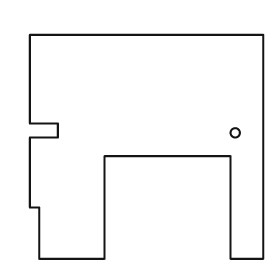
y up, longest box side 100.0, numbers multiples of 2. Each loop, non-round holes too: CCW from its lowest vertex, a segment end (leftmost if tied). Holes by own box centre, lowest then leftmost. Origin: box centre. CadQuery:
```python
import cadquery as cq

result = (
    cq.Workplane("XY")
    .moveTo(-46.0, -48.0)
    .lineTo(-18.0, -48.0)
    .lineTo(-18.0, -4.0)
    .lineTo(36.0, -4.0)
    .lineTo(36.0, -48.0)
    .lineTo(50.0, -48.0)
    .lineTo(50.0, 48.0)
    .lineTo(-50.0, 48.0)
    .lineTo(-50.0, 10.0)
    .lineTo(-38.0, 10.0)
    .lineTo(-38.0, 4.0)
    .lineTo(-50.0, 4.0)
    .lineTo(-50.0, -26.0)
    .lineTo(-46.0, -26.0)
    .close()
    .moveTo(38.0, 6.0)
    .circle(2.0)
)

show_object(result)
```